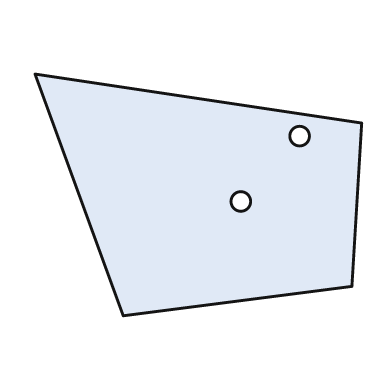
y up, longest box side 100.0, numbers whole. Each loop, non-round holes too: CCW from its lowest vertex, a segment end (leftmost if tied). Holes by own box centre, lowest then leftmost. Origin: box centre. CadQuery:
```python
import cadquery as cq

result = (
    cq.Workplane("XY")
    .moveTo(-23.0, -37.0)
    .lineTo(47.0, -28.0)
    .lineTo(50.0, 22.0)
    .lineTo(-50.0, 37.0)
    .close()
    .moveTo(13.0, -2.0)
    .circle(3.0)
    .moveTo(31.0, 18.0)
    .circle(3.0)
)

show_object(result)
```